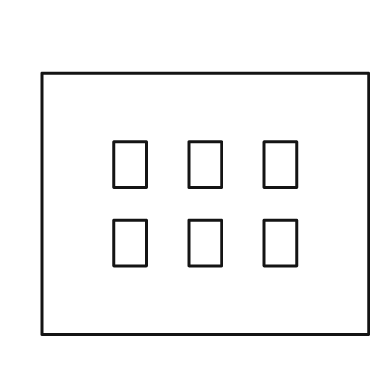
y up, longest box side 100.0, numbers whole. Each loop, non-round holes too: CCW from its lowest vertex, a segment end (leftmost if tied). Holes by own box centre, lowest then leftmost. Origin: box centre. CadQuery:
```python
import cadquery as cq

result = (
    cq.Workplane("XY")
    .moveTo(-50.0, -40.0)
    .lineTo(50.0, -40.0)
    .lineTo(50.0, 40.0)
    .lineTo(-50.0, 40.0)
    .close()
    .moveTo(-28.0, -19.0)
    .lineTo(-18.0, -19.0)
    .lineTo(-18.0, -5.0)
    .lineTo(-28.0, -5.0)
    .close()
    .moveTo(-5.0, -19.0)
    .lineTo(5.0, -19.0)
    .lineTo(5.0, -5.0)
    .lineTo(-5.0, -5.0)
    .close()
    .moveTo(18.0, -19.0)
    .lineTo(28.0, -19.0)
    .lineTo(28.0, -5.0)
    .lineTo(18.0, -5.0)
    .close()
    .moveTo(-28.0, 5.0)
    .lineTo(-18.0, 5.0)
    .lineTo(-18.0, 19.0)
    .lineTo(-28.0, 19.0)
    .close()
    .moveTo(-5.0, 5.0)
    .lineTo(5.0, 5.0)
    .lineTo(5.0, 19.0)
    .lineTo(-5.0, 19.0)
    .close()
    .moveTo(18.0, 5.0)
    .lineTo(28.0, 5.0)
    .lineTo(28.0, 19.0)
    .lineTo(18.0, 19.0)
    .close()
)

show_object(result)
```